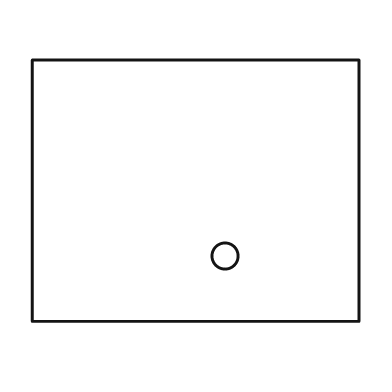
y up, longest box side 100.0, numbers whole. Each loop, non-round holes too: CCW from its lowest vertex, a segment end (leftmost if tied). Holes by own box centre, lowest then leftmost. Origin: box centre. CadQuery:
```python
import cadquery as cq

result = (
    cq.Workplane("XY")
    .moveTo(-50.0, -40.0)
    .lineTo(50.0, -40.0)
    .lineTo(50.0, 40.0)
    .lineTo(-50.0, 40.0)
    .close()
    .moveTo(9.0, -20.0)
    .circle(4.0)
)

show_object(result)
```